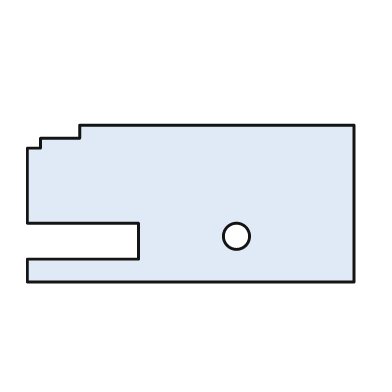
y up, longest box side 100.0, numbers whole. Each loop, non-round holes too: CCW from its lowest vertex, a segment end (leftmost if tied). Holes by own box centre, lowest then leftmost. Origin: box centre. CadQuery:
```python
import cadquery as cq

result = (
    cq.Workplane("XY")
    .moveTo(-50.0, -24.0)
    .lineTo(50.0, -24.0)
    .lineTo(50.0, 24.0)
    .lineTo(-34.0, 24.0)
    .lineTo(-34.0, 20.0)
    .lineTo(-46.0, 20.0)
    .lineTo(-46.0, 17.0)
    .lineTo(-50.0, 17.0)
    .lineTo(-50.0, -6.0)
    .lineTo(-16.0, -6.0)
    .lineTo(-16.0, -17.0)
    .lineTo(-50.0, -17.0)
    .close()
    .moveTo(14.0, -10.0)
    .circle(4.0)
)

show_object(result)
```